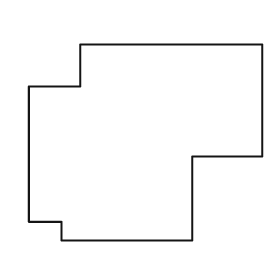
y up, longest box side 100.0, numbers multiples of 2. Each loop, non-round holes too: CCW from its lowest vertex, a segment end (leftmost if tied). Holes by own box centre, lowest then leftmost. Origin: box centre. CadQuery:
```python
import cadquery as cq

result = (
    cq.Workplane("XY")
    .moveTo(-36.0, -42.0)
    .lineTo(20.0, -42.0)
    .lineTo(20.0, -6.0)
    .lineTo(50.0, -6.0)
    .lineTo(50.0, 42.0)
    .lineTo(-28.0, 42.0)
    .lineTo(-28.0, 24.0)
    .lineTo(-50.0, 24.0)
    .lineTo(-50.0, -34.0)
    .lineTo(-36.0, -34.0)
    .close()
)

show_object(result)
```